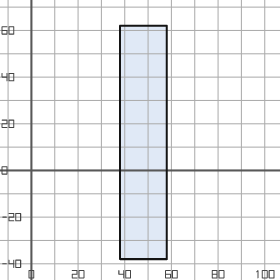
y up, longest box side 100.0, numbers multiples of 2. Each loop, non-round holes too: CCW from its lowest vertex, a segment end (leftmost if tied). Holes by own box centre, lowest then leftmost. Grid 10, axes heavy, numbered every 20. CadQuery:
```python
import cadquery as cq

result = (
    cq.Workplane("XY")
    .moveTo(38.0, -38.0)
    .lineTo(58.0, -38.0)
    .lineTo(58.0, 62.0)
    .lineTo(38.0, 62.0)
    .close()
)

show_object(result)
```